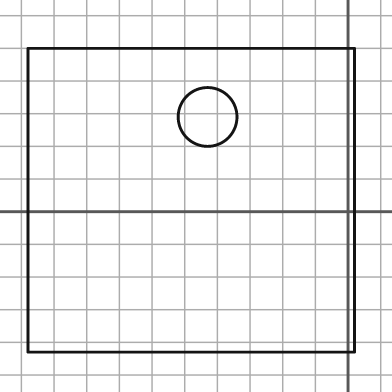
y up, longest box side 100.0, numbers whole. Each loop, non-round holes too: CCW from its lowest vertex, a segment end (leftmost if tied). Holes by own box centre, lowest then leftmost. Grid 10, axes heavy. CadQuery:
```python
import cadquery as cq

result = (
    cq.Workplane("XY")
    .moveTo(-98.0, -43.0)
    .lineTo(2.0, -43.0)
    .lineTo(2.0, 50.0)
    .lineTo(-98.0, 50.0)
    .close()
    .moveTo(-43.0, 29.0)
    .circle(9.0)
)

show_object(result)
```